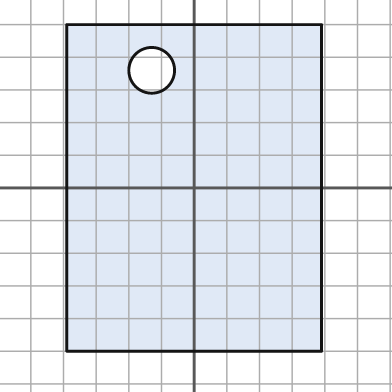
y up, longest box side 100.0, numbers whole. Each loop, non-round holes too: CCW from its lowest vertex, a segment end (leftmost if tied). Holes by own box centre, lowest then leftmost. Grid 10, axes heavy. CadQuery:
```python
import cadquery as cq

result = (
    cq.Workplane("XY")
    .moveTo(-39.0, -50.0)
    .lineTo(39.0, -50.0)
    .lineTo(39.0, 50.0)
    .lineTo(-39.0, 50.0)
    .close()
    .moveTo(-13.0, 36.0)
    .circle(7.0)
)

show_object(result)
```